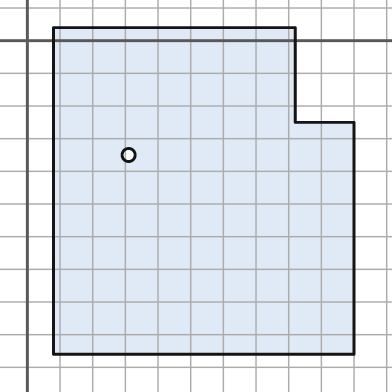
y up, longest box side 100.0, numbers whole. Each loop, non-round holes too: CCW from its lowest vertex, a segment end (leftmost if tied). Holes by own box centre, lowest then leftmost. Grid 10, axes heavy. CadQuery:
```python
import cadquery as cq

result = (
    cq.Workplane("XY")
    .moveTo(8.0, -96.0)
    .lineTo(100.0, -96.0)
    .lineTo(100.0, -25.0)
    .lineTo(82.0, -25.0)
    .lineTo(82.0, 4.0)
    .lineTo(8.0, 4.0)
    .close()
    .moveTo(31.0, -35.0)
    .circle(2.0)
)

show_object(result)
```